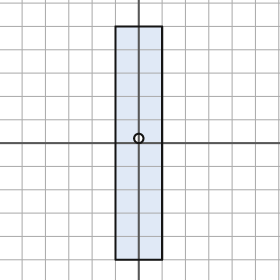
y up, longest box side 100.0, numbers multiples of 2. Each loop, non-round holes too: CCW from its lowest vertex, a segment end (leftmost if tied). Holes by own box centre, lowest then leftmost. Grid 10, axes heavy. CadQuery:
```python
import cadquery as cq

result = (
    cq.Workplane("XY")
    .moveTo(-10.0, -50.0)
    .lineTo(10.0, -50.0)
    .lineTo(10.0, 50.0)
    .lineTo(-10.0, 50.0)
    .close()
    .moveTo(0.0, 2.0)
    .circle(2.0)
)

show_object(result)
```